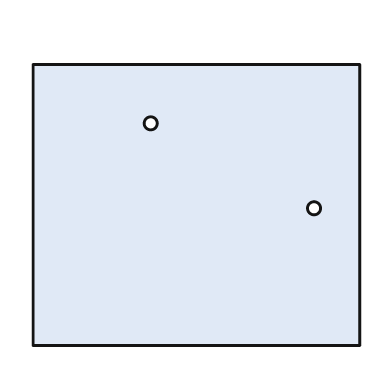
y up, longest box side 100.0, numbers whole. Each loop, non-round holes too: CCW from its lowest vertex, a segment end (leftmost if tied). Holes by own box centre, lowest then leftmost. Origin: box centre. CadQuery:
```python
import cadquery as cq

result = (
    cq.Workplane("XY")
    .moveTo(-50.0, -43.0)
    .lineTo(50.0, -43.0)
    .lineTo(50.0, 43.0)
    .lineTo(-50.0, 43.0)
    .close()
    .moveTo(36.0, -1.0)
    .circle(2.0)
    .moveTo(-14.0, 25.0)
    .circle(2.0)
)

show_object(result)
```